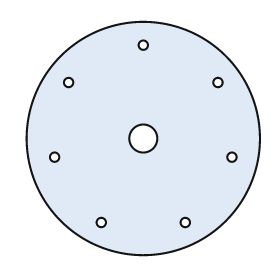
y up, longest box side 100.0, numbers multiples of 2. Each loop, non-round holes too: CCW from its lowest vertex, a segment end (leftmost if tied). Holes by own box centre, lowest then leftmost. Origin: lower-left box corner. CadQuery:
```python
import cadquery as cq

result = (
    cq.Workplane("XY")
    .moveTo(50.0, 50.0)
    .circle(50.0)
    .moveTo(32.0, 14.0)
    .circle(2.0)
    .moveTo(68.0, 14.0)
    .circle(2.0)
    .moveTo(12.0, 42.0)
    .circle(2.0)
    .moveTo(88.0, 42.0)
    .circle(2.0)
    .moveTo(50.0, 50.0)
    .circle(6.0)
    .moveTo(18.0, 74.0)
    .circle(2.0)
    .moveTo(82.0, 74.0)
    .circle(2.0)
    .moveTo(50.0, 90.0)
    .circle(2.0)
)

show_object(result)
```